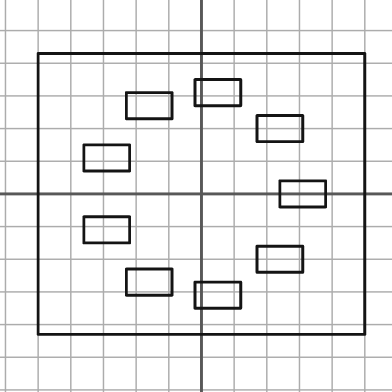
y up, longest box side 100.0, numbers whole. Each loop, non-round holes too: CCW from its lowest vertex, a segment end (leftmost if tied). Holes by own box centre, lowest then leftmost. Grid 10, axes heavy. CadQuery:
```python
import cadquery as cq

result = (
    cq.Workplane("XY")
    .moveTo(-50.0, -43.0)
    .lineTo(50.0, -43.0)
    .lineTo(50.0, 43.0)
    .lineTo(-50.0, 43.0)
    .close()
    .moveTo(-2.0, -35.0)
    .lineTo(12.0, -35.0)
    .lineTo(12.0, -27.0)
    .lineTo(-2.0, -27.0)
    .close()
    .moveTo(-23.0, -31.0)
    .lineTo(-9.0, -31.0)
    .lineTo(-9.0, -23.0)
    .lineTo(-23.0, -23.0)
    .close()
    .moveTo(17.0, -24.0)
    .lineTo(31.0, -24.0)
    .lineTo(31.0, -16.0)
    .lineTo(17.0, -16.0)
    .close()
    .moveTo(-36.0, -15.0)
    .lineTo(-22.0, -15.0)
    .lineTo(-22.0, -7.0)
    .lineTo(-36.0, -7.0)
    .close()
    .moveTo(24.0, -4.0)
    .lineTo(38.0, -4.0)
    .lineTo(38.0, 4.0)
    .lineTo(24.0, 4.0)
    .close()
    .moveTo(-36.0, 7.0)
    .lineTo(-22.0, 7.0)
    .lineTo(-22.0, 15.0)
    .lineTo(-36.0, 15.0)
    .close()
    .moveTo(17.0, 16.0)
    .lineTo(31.0, 16.0)
    .lineTo(31.0, 24.0)
    .lineTo(17.0, 24.0)
    .close()
    .moveTo(-23.0, 23.0)
    .lineTo(-9.0, 23.0)
    .lineTo(-9.0, 31.0)
    .lineTo(-23.0, 31.0)
    .close()
    .moveTo(-2.0, 27.0)
    .lineTo(12.0, 27.0)
    .lineTo(12.0, 35.0)
    .lineTo(-2.0, 35.0)
    .close()
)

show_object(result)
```